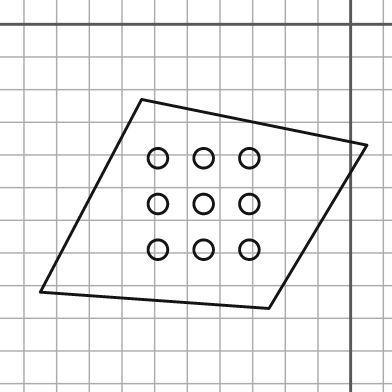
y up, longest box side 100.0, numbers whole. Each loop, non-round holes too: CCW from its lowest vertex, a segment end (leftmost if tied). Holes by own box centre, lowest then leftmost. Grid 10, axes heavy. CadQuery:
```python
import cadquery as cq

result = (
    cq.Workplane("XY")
    .moveTo(-25.0, -87.0)
    .lineTo(5.0, -37.0)
    .lineTo(-64.0, -23.0)
    .lineTo(-95.0, -82.0)
    .close()
    .moveTo(-59.0, -69.0)
    .circle(3.0)
    .moveTo(-45.0, -69.0)
    .circle(3.0)
    .moveTo(-31.0, -69.0)
    .circle(3.0)
    .moveTo(-59.0, -55.0)
    .circle(3.0)
    .moveTo(-45.0, -55.0)
    .circle(3.0)
    .moveTo(-31.0, -55.0)
    .circle(3.0)
    .moveTo(-59.0, -41.0)
    .circle(3.0)
    .moveTo(-45.0, -41.0)
    .circle(3.0)
    .moveTo(-31.0, -41.0)
    .circle(3.0)
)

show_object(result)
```